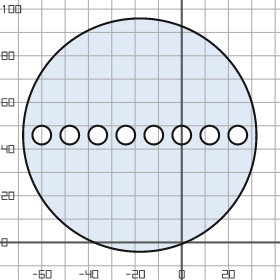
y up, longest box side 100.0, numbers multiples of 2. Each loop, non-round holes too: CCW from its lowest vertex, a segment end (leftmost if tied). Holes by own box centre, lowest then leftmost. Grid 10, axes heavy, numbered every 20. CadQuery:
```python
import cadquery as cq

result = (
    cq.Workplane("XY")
    .moveTo(-18.0, 46.0)
    .circle(50.0)
    .moveTo(-60.0, 46.0)
    .circle(4.0)
    .moveTo(-48.0, 46.0)
    .circle(4.0)
    .moveTo(-36.0, 46.0)
    .circle(4.0)
    .moveTo(-24.0, 46.0)
    .circle(4.0)
    .moveTo(-12.0, 46.0)
    .circle(4.0)
    .moveTo(0.0, 46.0)
    .circle(4.0)
    .moveTo(12.0, 46.0)
    .circle(4.0)
    .moveTo(24.0, 46.0)
    .circle(4.0)
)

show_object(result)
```